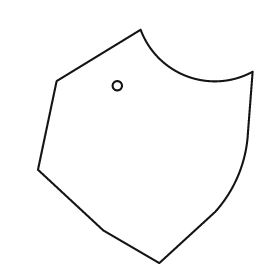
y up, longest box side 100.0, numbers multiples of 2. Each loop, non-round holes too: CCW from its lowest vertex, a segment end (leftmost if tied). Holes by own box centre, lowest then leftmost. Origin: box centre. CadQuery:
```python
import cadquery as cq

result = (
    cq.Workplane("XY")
    .moveTo(6.0, -50.0)
    .lineTo(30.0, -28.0)
    .threePointArc((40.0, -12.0), (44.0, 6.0))
    .lineTo(46.0, 32.0)
    .threePointArc((18.0, 30.0), (-2.0, 50.0))
    .lineTo(-38.0, 28.0)
    .lineTo(-46.0, -10.0)
    .lineTo(-18.0, -36.0)
    .close()
    .moveTo(-12.0, 26.0)
    .circle(2.0)
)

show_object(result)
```